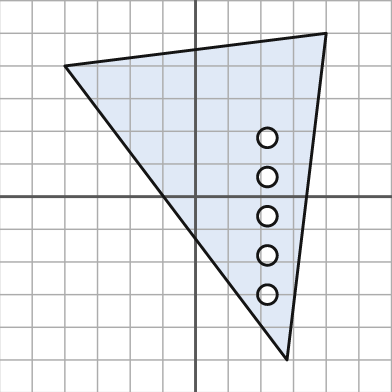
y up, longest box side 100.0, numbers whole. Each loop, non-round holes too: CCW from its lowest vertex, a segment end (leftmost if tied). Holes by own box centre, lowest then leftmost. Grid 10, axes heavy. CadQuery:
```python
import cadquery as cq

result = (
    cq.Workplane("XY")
    .moveTo(28.0, -50.0)
    .lineTo(40.0, 50.0)
    .lineTo(-40.0, 40.0)
    .close()
    .moveTo(22.0, -30.0)
    .circle(3.0)
    .moveTo(22.0, -18.0)
    .circle(3.0)
    .moveTo(22.0, -6.0)
    .circle(3.0)
    .moveTo(22.0, 6.0)
    .circle(3.0)
    .moveTo(22.0, 18.0)
    .circle(3.0)
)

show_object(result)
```